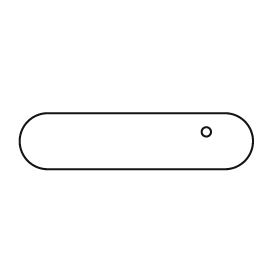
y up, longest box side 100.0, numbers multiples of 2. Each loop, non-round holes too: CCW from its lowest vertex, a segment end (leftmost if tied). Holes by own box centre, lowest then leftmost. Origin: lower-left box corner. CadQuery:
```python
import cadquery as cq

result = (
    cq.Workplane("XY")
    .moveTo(12.0, 0.0)
    .lineTo(88.0, 0.0)
    .threePointArc((100.0, 12.0), (88.0, 24.0))
    .lineTo(12.0, 24.0)
    .threePointArc((0.0, 12.0), (12.0, 0.0))
    .close()
    .moveTo(80.0, 16.0)
    .circle(2.0)
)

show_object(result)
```